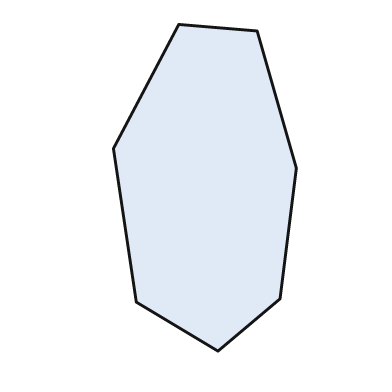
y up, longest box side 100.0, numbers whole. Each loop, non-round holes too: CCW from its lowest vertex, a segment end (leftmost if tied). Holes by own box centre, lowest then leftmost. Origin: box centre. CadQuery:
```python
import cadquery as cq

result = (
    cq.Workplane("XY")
    .moveTo(4.0, -50.0)
    .lineTo(23.0, -34.0)
    .lineTo(28.0, 6.0)
    .lineTo(16.0, 48.0)
    .lineTo(-8.0, 50.0)
    .lineTo(-28.0, 12.0)
    .lineTo(-21.0, -35.0)
    .close()
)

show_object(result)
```